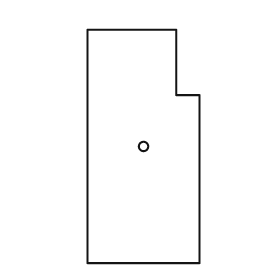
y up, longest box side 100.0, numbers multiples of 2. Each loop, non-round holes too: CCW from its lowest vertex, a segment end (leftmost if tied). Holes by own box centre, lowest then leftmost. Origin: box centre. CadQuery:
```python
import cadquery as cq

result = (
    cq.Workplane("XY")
    .moveTo(-24.0, -50.0)
    .lineTo(24.0, -50.0)
    .lineTo(24.0, 22.0)
    .lineTo(14.0, 22.0)
    .lineTo(14.0, 50.0)
    .lineTo(-24.0, 50.0)
    .close()
    .moveTo(0.0, 0.0)
    .circle(2.0)
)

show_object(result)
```